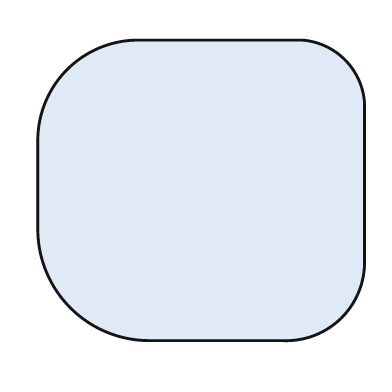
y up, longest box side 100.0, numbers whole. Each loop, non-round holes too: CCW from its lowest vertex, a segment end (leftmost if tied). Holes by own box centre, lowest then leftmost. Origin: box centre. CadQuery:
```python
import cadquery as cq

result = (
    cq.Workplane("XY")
    .moveTo(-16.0, -46.0)
    .lineTo(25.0, -46.0)
    .threePointArc((43.0, -39.0), (50.0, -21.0))
    .lineTo(50.0, 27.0)
    .threePointArc((44.0, 40.0), (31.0, 46.0))
    .lineTo(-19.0, 46.0)
    .threePointArc((-41.0, 37.0), (-50.0, 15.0))
    .lineTo(-50.0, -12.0)
    .threePointArc((-40.0, -36.0), (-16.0, -46.0))
    .close()
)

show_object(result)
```